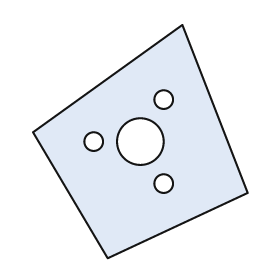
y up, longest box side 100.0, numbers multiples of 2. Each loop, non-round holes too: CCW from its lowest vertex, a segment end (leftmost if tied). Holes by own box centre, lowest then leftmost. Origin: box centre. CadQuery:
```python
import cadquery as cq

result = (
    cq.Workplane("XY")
    .moveTo(-14.0, -50.0)
    .lineTo(46.0, -22.0)
    .lineTo(18.0, 50.0)
    .lineTo(-46.0, 4.0)
    .close()
    .moveTo(10.0, -18.0)
    .circle(4.0)
    .moveTo(-20.0, 0.0)
    .circle(4.0)
    .moveTo(0.0, 0.0)
    .circle(10.0)
    .moveTo(10.0, 18.0)
    .circle(4.0)
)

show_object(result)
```